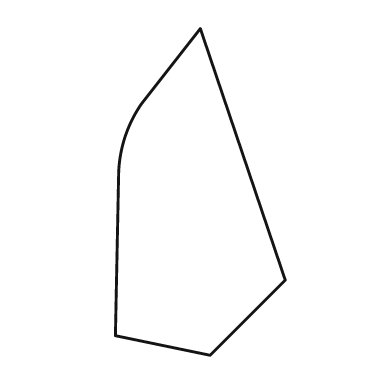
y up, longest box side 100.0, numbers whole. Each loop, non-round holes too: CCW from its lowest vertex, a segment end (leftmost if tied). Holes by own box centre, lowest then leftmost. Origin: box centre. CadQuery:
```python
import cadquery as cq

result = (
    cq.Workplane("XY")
    .moveTo(3.0, -50.0)
    .lineTo(26.0, -27.0)
    .lineTo(0.0, 50.0)
    .lineTo(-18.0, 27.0)
    .threePointArc((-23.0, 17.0), (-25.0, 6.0))
    .lineTo(-26.0, -44.0)
    .close()
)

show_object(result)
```